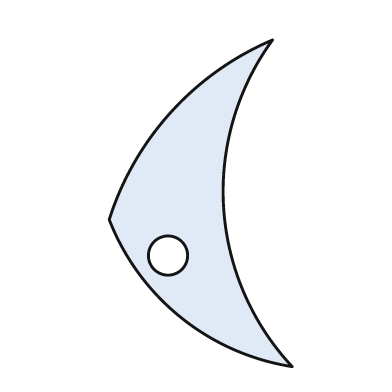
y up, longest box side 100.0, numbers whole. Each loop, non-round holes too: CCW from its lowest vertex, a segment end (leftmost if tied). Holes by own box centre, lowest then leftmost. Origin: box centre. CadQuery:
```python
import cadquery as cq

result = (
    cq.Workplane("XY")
    .moveTo(28.0, -50.0)
    .threePointArc((7.0, -1.0), (22.0, 50.0))
    .threePointArc((-9.0, 28.0), (-28.0, -5.0))
    .threePointArc((-6.0, -35.0), (28.0, -50.0))
    .close()
    .moveTo(-10.0, -16.0)
    .circle(6.0)
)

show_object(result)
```